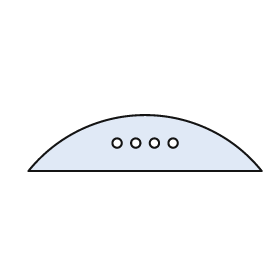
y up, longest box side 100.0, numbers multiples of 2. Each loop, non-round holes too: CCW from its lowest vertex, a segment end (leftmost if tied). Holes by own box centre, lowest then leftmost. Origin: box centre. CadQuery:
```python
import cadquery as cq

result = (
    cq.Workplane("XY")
    .moveTo(-50.0, -12.0)
    .lineTo(50.0, -12.0)
    .threePointArc((0.0, 12.0), (-50.0, -12.0))
    .close()
    .moveTo(-12.0, 0.0)
    .circle(2.0)
    .moveTo(-4.0, 0.0)
    .circle(2.0)
    .moveTo(4.0, 0.0)
    .circle(2.0)
    .moveTo(12.0, 0.0)
    .circle(2.0)
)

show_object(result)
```